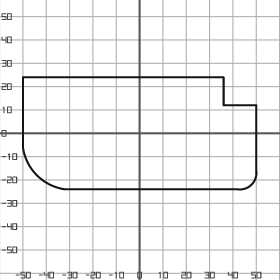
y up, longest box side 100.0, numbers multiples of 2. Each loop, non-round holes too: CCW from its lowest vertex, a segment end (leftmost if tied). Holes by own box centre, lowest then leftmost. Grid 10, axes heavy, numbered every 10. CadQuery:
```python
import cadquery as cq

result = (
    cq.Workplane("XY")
    .moveTo(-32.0, -24.0)
    .lineTo(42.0, -24.0)
    .threePointArc((48.0, -22.0), (50.0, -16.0))
    .lineTo(50.0, 12.0)
    .lineTo(36.0, 12.0)
    .lineTo(36.0, 24.0)
    .lineTo(-50.0, 24.0)
    .lineTo(-50.0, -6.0)
    .threePointArc((-44.0, -18.0), (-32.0, -24.0))
    .close()
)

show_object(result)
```